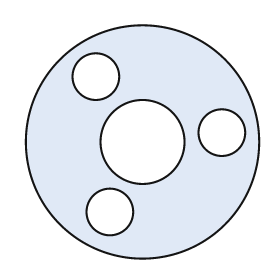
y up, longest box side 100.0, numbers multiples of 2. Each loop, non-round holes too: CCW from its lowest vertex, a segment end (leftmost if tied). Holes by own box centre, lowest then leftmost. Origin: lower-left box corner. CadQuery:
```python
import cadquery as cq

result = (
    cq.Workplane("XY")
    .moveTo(50.0, 50.0)
    .circle(50.0)
    .moveTo(36.0, 20.0)
    .circle(10.0)
    .moveTo(50.0, 50.0)
    .circle(18.0)
    .moveTo(84.0, 54.0)
    .circle(10.0)
    .moveTo(30.0, 78.0)
    .circle(10.0)
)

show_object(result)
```